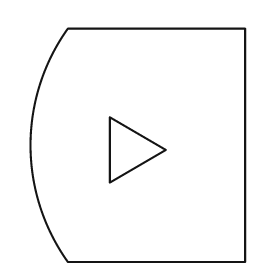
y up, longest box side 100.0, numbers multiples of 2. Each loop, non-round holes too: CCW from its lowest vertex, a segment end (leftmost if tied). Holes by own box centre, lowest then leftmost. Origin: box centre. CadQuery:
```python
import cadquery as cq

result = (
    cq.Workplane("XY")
    .moveTo(-30.0, -50.0)
    .lineTo(46.0, -50.0)
    .lineTo(46.0, 50.0)
    .lineTo(-30.0, 50.0)
    .threePointArc((-46.0, 0.0), (-30.0, -50.0))
    .close()
    .moveTo(-12.0, -16.0)
    .lineTo(12.0, -2.0)
    .lineTo(-12.0, 12.0)
    .close()
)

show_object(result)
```